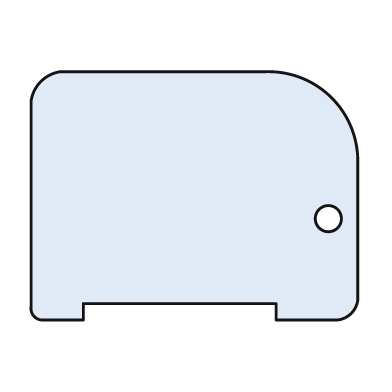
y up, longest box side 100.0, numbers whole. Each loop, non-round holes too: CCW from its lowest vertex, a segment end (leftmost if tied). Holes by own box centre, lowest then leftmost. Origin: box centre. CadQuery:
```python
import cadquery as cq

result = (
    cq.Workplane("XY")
    .moveTo(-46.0, -38.0)
    .lineTo(-34.0, -38.0)
    .lineTo(-34.0, -33.0)
    .lineTo(25.0, -33.0)
    .lineTo(25.0, -38.0)
    .lineTo(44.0, -38.0)
    .threePointArc((48.0, -36.0), (50.0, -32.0))
    .lineTo(50.0, 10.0)
    .threePointArc((42.0, 30.0), (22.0, 38.0))
    .lineTo(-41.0, 38.0)
    .threePointArc((-47.0, 35.0), (-50.0, 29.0))
    .lineTo(-50.0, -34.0)
    .threePointArc((-49.0, -37.0), (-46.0, -38.0))
    .close()
    .moveTo(41.0, -7.0)
    .circle(4.0)
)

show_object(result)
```